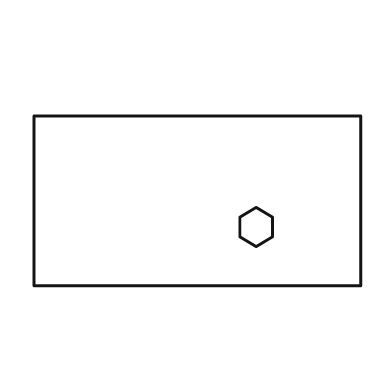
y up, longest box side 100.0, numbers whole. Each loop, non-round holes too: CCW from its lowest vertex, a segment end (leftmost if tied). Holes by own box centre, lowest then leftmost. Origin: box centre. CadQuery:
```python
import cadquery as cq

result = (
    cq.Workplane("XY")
    .moveTo(-50.0, -26.0)
    .lineTo(50.0, -26.0)
    .lineTo(50.0, 26.0)
    .lineTo(-50.0, 26.0)
    .close()
    .moveTo(18.0, -14.0)
    .lineTo(23.0, -11.0)
    .lineTo(23.0, -5.0)
    .lineTo(18.0, -2.0)
    .lineTo(13.0, -5.0)
    .lineTo(13.0, -11.0)
    .close()
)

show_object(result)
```